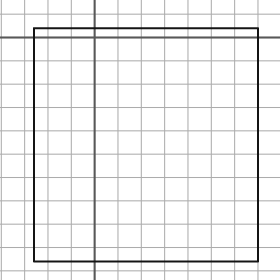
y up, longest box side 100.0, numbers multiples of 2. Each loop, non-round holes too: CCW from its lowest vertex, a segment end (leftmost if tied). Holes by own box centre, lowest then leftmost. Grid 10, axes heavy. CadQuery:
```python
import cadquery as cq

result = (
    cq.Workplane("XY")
    .moveTo(-26.0, -96.0)
    .lineTo(70.0, -96.0)
    .lineTo(70.0, 4.0)
    .lineTo(-26.0, 4.0)
    .close()
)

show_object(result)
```